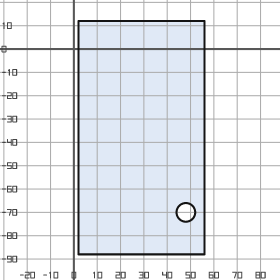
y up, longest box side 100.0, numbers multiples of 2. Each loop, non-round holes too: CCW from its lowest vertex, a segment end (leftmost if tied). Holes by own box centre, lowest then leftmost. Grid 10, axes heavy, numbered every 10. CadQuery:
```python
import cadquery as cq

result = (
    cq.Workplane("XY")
    .moveTo(2.0, -88.0)
    .lineTo(56.0, -88.0)
    .lineTo(56.0, 12.0)
    .lineTo(2.0, 12.0)
    .close()
    .moveTo(48.0, -70.0)
    .circle(4.0)
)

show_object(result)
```